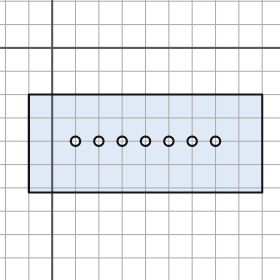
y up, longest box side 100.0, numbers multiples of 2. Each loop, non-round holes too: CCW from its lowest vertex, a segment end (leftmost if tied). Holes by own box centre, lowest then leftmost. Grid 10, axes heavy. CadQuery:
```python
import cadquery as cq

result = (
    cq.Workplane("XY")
    .moveTo(-10.0, -62.0)
    .lineTo(90.0, -62.0)
    .lineTo(90.0, -20.0)
    .lineTo(-10.0, -20.0)
    .close()
    .moveTo(10.0, -40.0)
    .circle(2.0)
    .moveTo(20.0, -40.0)
    .circle(2.0)
    .moveTo(30.0, -40.0)
    .circle(2.0)
    .moveTo(40.0, -40.0)
    .circle(2.0)
    .moveTo(50.0, -40.0)
    .circle(2.0)
    .moveTo(60.0, -40.0)
    .circle(2.0)
    .moveTo(70.0, -40.0)
    .circle(2.0)
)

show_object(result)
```